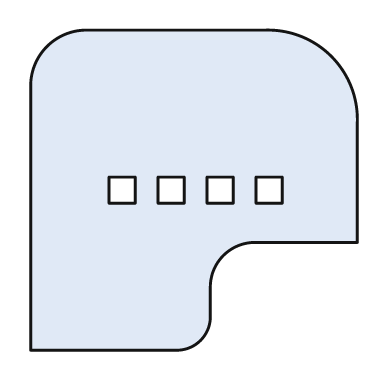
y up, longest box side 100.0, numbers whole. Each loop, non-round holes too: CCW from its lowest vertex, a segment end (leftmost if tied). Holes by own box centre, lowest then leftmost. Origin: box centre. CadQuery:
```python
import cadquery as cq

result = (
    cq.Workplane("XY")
    .moveTo(-50.0, -49.0)
    .lineTo(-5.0, -49.0)
    .threePointArc((2.0, -46.0), (5.0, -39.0))
    .lineTo(5.0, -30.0)
    .threePointArc((9.0, -20.0), (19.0, -16.0))
    .lineTo(50.0, -16.0)
    .lineTo(50.0, 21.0)
    .threePointArc((42.0, 41.0), (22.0, 49.0))
    .lineTo(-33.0, 49.0)
    .threePointArc((-45.0, 44.0), (-50.0, 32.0))
    .close()
    .moveTo(-26.0, -4.0)
    .lineTo(-18.0, -4.0)
    .lineTo(-18.0, 4.0)
    .lineTo(-26.0, 4.0)
    .close()
    .moveTo(-11.0, -4.0)
    .lineTo(-3.0, -4.0)
    .lineTo(-3.0, 4.0)
    .lineTo(-11.0, 4.0)
    .close()
    .moveTo(4.0, -4.0)
    .lineTo(12.0, -4.0)
    .lineTo(12.0, 4.0)
    .lineTo(4.0, 4.0)
    .close()
    .moveTo(19.0, -4.0)
    .lineTo(27.0, -4.0)
    .lineTo(27.0, 4.0)
    .lineTo(19.0, 4.0)
    .close()
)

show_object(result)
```